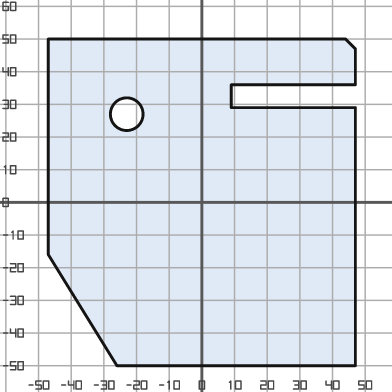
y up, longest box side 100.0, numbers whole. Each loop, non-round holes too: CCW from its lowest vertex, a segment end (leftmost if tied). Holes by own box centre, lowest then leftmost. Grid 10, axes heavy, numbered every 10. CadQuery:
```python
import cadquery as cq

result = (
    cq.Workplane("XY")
    .moveTo(-26.0, -50.0)
    .lineTo(47.0, -50.0)
    .lineTo(47.0, 29.0)
    .lineTo(9.0, 29.0)
    .lineTo(9.0, 36.0)
    .lineTo(47.0, 36.0)
    .lineTo(47.0, 47.0)
    .lineTo(44.0, 50.0)
    .lineTo(-47.0, 50.0)
    .lineTo(-47.0, -16.0)
    .close()
    .moveTo(-23.0, 27.0)
    .circle(5.0)
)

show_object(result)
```